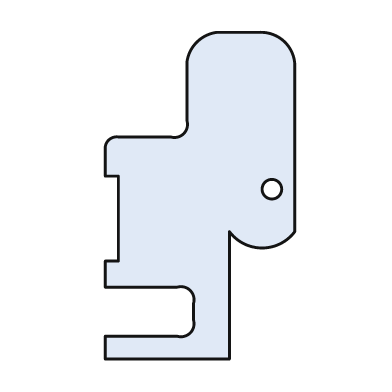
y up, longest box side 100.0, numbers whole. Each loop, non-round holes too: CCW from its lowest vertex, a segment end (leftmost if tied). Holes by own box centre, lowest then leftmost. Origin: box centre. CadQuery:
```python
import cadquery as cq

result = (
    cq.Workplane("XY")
    .moveTo(-29.0, -50.0)
    .lineTo(9.0, -50.0)
    .lineTo(9.0, -11.0)
    .threePointArc((19.0, -16.0), (29.0, -11.0))
    .lineTo(29.0, 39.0)
    .threePointArc((26.0, 47.0), (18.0, 50.0))
    .lineTo(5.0, 50.0)
    .threePointArc((-1.0, 47.0), (-4.0, 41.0))
    .lineTo(-4.0, 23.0)
    .threePointArc((-5.0, 19.0), (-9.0, 18.0))
    .lineTo(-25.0, 18.0)
    .threePointArc((-28.0, 17.0), (-29.0, 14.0))
    .lineTo(-29.0, 6.0)
    .lineTo(-25.0, 6.0)
    .lineTo(-25.0, -20.0)
    .lineTo(-29.0, -20.0)
    .lineTo(-29.0, -28.0)
    .lineTo(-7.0, -28.0)
    .threePointArc((-3.0, -29.0), (-2.0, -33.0))
    .lineTo(-2.0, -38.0)
    .threePointArc((-3.0, -42.0), (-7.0, -43.0))
    .lineTo(-29.0, -43.0)
    .close()
    .moveTo(22.0, 2.0)
    .circle(3.0)
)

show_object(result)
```